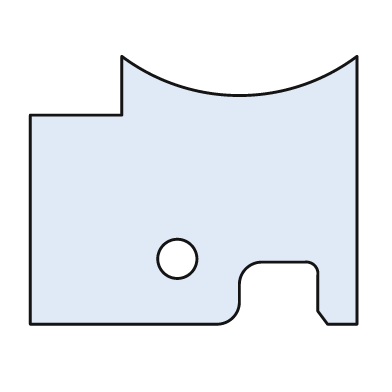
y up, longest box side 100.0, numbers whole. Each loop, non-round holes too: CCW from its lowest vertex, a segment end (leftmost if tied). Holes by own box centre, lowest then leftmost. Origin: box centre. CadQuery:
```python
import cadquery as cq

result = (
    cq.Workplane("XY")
    .moveTo(-50.0, -41.0)
    .lineTo(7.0, -41.0)
    .threePointArc((12.0, -39.0), (14.0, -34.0))
    .lineTo(14.0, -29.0)
    .threePointArc((16.0, -24.0), (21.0, -22.0))
    .lineTo(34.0, -22.0)
    .threePointArc((37.0, -23.0), (38.0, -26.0))
    .lineTo(38.0, -37.0)
    .lineTo(41.0, -41.0)
    .lineTo(50.0, -41.0)
    .lineTo(50.0, 41.0)
    .threePointArc((14.0, 29.0), (-22.0, 41.0))
    .lineTo(-22.0, 23.0)
    .lineTo(-50.0, 23.0)
    .close()
    .moveTo(-5.0, -21.0)
    .circle(6.0)
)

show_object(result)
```